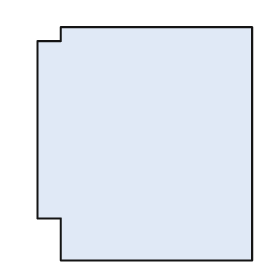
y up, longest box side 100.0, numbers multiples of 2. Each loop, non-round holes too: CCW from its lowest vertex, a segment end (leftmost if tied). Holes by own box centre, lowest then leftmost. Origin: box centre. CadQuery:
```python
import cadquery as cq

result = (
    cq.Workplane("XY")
    .moveTo(-36.0, -50.0)
    .lineTo(46.0, -50.0)
    .lineTo(46.0, 50.0)
    .lineTo(-36.0, 50.0)
    .lineTo(-36.0, 44.0)
    .lineTo(-46.0, 44.0)
    .lineTo(-46.0, -32.0)
    .lineTo(-36.0, -32.0)
    .close()
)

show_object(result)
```